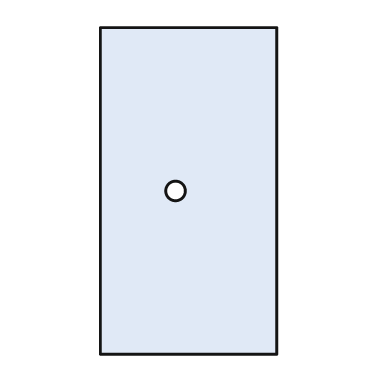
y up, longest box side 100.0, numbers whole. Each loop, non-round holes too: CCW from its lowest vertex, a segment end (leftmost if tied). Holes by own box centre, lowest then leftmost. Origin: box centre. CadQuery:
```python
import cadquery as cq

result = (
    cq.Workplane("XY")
    .moveTo(-27.0, -50.0)
    .lineTo(27.0, -50.0)
    .lineTo(27.0, 50.0)
    .lineTo(-27.0, 50.0)
    .close()
    .moveTo(-4.0, 0.0)
    .circle(3.0)
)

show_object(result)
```